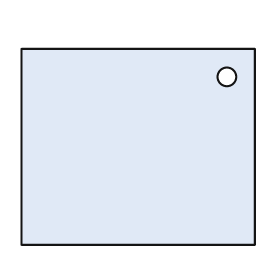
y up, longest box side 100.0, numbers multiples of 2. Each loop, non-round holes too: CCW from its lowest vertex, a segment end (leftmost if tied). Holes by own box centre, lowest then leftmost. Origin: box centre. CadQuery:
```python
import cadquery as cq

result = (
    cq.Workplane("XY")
    .moveTo(-50.0, -42.0)
    .lineTo(50.0, -42.0)
    .lineTo(50.0, 42.0)
    .lineTo(-50.0, 42.0)
    .close()
    .moveTo(38.0, 30.0)
    .circle(4.0)
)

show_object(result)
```